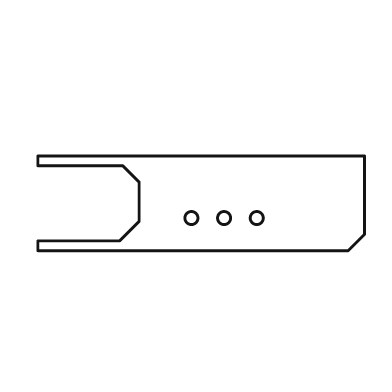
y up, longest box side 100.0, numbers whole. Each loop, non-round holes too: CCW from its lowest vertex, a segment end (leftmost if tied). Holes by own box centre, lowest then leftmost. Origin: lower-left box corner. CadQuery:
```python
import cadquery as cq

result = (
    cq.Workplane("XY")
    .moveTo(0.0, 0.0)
    .lineTo(95.0, 0.0)
    .lineTo(100.0, 5.0)
    .lineTo(100.0, 29.0)
    .lineTo(0.0, 29.0)
    .lineTo(0.0, 26.0)
    .lineTo(26.0, 26.0)
    .lineTo(31.0, 21.0)
    .lineTo(31.0, 9.0)
    .lineTo(25.0, 3.0)
    .lineTo(0.0, 3.0)
    .close()
    .moveTo(47.0, 10.0)
    .circle(2.0)
    .moveTo(57.0, 10.0)
    .circle(2.0)
    .moveTo(67.0, 10.0)
    .circle(2.0)
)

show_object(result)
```